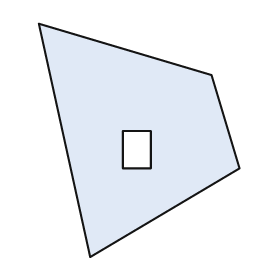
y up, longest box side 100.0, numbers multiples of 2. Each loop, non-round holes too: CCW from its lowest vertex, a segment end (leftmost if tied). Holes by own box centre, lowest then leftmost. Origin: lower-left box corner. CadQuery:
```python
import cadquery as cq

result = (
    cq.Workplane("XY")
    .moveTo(22.0, 0.0)
    .lineTo(86.0, 38.0)
    .lineTo(74.0, 78.0)
    .lineTo(0.0, 100.0)
    .close()
    .moveTo(36.0, 38.0)
    .lineTo(48.0, 38.0)
    .lineTo(48.0, 54.0)
    .lineTo(36.0, 54.0)
    .close()
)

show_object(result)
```